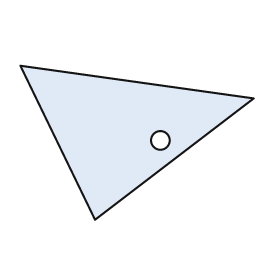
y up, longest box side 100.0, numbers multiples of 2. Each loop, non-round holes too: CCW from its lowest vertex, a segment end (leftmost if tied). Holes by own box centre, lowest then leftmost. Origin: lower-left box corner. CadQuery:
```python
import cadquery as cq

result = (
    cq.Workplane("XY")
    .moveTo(32.0, 0.0)
    .lineTo(100.0, 52.0)
    .lineTo(0.0, 66.0)
    .close()
    .moveTo(60.0, 34.0)
    .circle(4.0)
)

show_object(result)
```